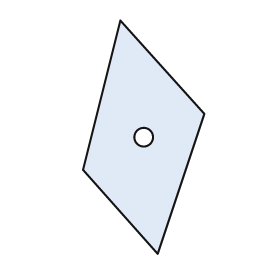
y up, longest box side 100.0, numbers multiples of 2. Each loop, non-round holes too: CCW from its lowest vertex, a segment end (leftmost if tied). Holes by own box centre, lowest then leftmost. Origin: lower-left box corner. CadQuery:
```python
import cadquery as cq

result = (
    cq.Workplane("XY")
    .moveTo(32.0, 0.0)
    .lineTo(52.0, 60.0)
    .lineTo(16.0, 100.0)
    .lineTo(0.0, 36.0)
    .close()
    .moveTo(26.0, 50.0)
    .circle(4.0)
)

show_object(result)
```